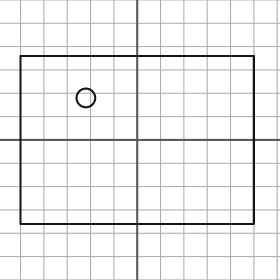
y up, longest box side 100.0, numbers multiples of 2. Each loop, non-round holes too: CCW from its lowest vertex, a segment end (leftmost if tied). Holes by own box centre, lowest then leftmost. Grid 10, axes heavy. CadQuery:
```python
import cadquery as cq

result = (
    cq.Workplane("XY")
    .moveTo(-50.0, -36.0)
    .lineTo(50.0, -36.0)
    .lineTo(50.0, 36.0)
    .lineTo(-50.0, 36.0)
    .close()
    .moveTo(-22.0, 18.0)
    .circle(4.0)
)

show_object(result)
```